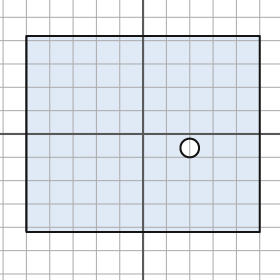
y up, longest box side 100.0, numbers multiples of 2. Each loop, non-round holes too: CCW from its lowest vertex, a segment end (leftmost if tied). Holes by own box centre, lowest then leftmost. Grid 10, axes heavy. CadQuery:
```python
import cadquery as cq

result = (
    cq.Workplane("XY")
    .moveTo(-50.0, -42.0)
    .lineTo(50.0, -42.0)
    .lineTo(50.0, 42.0)
    .lineTo(-50.0, 42.0)
    .close()
    .moveTo(20.0, -6.0)
    .circle(4.0)
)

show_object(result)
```